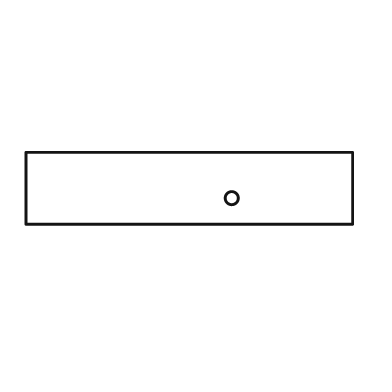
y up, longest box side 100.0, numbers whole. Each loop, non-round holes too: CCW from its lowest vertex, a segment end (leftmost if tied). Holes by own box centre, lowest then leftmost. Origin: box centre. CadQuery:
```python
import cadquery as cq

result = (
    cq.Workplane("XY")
    .moveTo(-50.0, -11.0)
    .lineTo(50.0, -11.0)
    .lineTo(50.0, 11.0)
    .lineTo(-50.0, 11.0)
    .close()
    .moveTo(13.0, -3.0)
    .circle(2.0)
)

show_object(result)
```